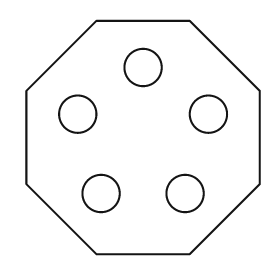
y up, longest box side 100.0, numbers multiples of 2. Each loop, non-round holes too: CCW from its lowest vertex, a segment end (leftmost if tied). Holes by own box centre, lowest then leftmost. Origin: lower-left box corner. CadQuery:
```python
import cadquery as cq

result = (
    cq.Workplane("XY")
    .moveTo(30.0, 0.0)
    .lineTo(70.0, 0.0)
    .lineTo(100.0, 30.0)
    .lineTo(100.0, 70.0)
    .lineTo(70.0, 100.0)
    .lineTo(30.0, 100.0)
    .lineTo(0.0, 70.0)
    .lineTo(0.0, 30.0)
    .close()
    .moveTo(32.0, 26.0)
    .circle(8.0)
    .moveTo(68.0, 26.0)
    .circle(8.0)
    .moveTo(22.0, 60.0)
    .circle(8.0)
    .moveTo(78.0, 60.0)
    .circle(8.0)
    .moveTo(50.0, 80.0)
    .circle(8.0)
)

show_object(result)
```